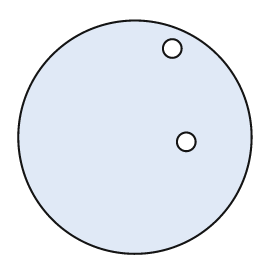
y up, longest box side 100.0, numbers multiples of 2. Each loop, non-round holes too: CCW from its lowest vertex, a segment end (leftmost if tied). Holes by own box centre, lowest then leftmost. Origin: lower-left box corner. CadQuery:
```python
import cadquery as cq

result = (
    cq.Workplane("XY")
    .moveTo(50.0, 50.0)
    .circle(50.0)
    .moveTo(72.0, 48.0)
    .circle(4.0)
    .moveTo(66.0, 88.0)
    .circle(4.0)
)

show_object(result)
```